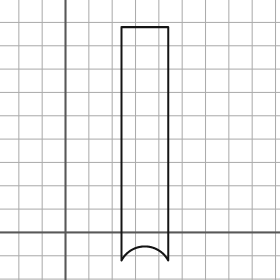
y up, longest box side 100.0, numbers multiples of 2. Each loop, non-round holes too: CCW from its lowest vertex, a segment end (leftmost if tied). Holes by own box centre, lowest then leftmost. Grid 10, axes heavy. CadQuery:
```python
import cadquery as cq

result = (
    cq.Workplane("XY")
    .moveTo(24.0, -12.0)
    .threePointArc((34.0, -6.0), (44.0, -12.0))
    .lineTo(44.0, 88.0)
    .lineTo(24.0, 88.0)
    .close()
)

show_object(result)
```